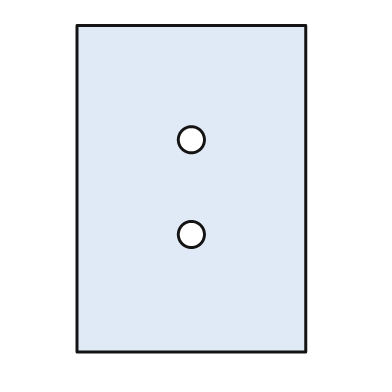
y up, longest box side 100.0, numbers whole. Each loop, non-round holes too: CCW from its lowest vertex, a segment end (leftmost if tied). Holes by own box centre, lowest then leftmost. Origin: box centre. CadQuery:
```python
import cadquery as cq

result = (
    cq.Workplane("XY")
    .moveTo(-35.0, -50.0)
    .lineTo(35.0, -50.0)
    .lineTo(35.0, 50.0)
    .lineTo(-35.0, 50.0)
    .close()
    .moveTo(0.0, -14.0)
    .circle(4.0)
    .moveTo(0.0, 15.0)
    .circle(4.0)
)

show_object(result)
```